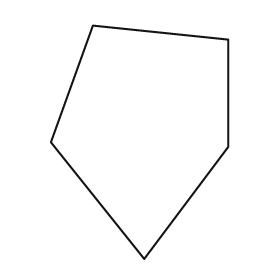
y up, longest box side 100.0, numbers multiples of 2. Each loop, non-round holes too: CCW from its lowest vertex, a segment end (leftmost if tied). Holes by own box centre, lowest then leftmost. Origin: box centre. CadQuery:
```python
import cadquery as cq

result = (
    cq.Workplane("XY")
    .moveTo(2.0, -50.0)
    .lineTo(38.0, -2.0)
    .lineTo(38.0, 44.0)
    .lineTo(-20.0, 50.0)
    .lineTo(-38.0, 0.0)
    .close()
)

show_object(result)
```